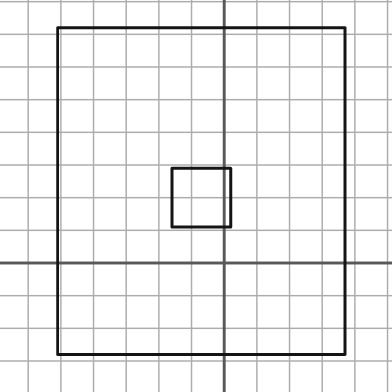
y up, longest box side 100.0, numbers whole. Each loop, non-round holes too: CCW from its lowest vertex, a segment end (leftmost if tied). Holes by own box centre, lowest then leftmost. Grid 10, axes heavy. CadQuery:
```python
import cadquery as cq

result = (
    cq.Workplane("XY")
    .moveTo(-51.0, -28.0)
    .lineTo(37.0, -28.0)
    .lineTo(37.0, 72.0)
    .lineTo(-51.0, 72.0)
    .close()
    .moveTo(-16.0, 11.0)
    .lineTo(2.0, 11.0)
    .lineTo(2.0, 29.0)
    .lineTo(-16.0, 29.0)
    .close()
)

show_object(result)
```